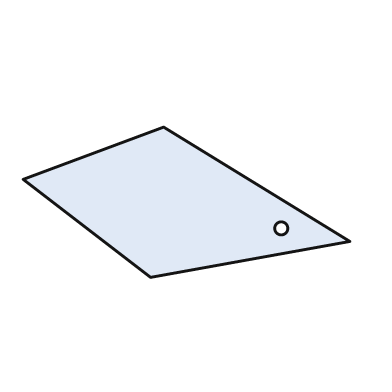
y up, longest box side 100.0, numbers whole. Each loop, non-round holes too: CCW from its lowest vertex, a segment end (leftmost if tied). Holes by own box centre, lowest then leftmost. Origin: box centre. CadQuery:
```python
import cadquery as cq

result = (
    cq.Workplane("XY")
    .moveTo(-11.0, -23.0)
    .lineTo(50.0, -12.0)
    .lineTo(-7.0, 23.0)
    .lineTo(-50.0, 7.0)
    .close()
    .moveTo(29.0, -8.0)
    .circle(2.0)
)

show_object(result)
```